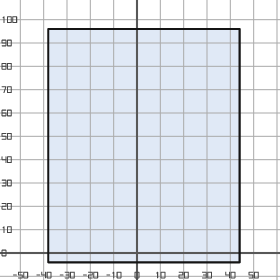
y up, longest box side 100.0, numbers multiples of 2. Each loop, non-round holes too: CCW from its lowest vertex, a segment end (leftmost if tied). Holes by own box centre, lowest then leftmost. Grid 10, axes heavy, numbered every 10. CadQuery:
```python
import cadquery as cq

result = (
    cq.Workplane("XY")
    .moveTo(-38.0, -4.0)
    .lineTo(44.0, -4.0)
    .lineTo(44.0, 96.0)
    .lineTo(-38.0, 96.0)
    .close()
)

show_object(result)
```